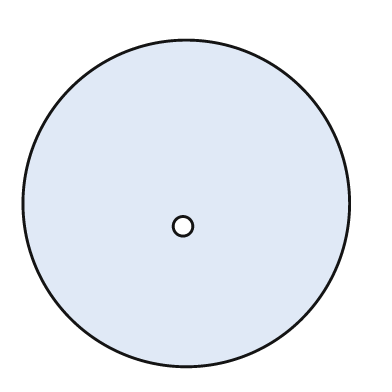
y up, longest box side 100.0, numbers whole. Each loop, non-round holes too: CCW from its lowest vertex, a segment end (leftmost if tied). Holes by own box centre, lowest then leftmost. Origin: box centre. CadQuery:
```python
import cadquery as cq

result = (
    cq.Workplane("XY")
    .moveTo(0.0, 0.0)
    .circle(50.0)
    .moveTo(-1.0, -7.0)
    .circle(3.0)
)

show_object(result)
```